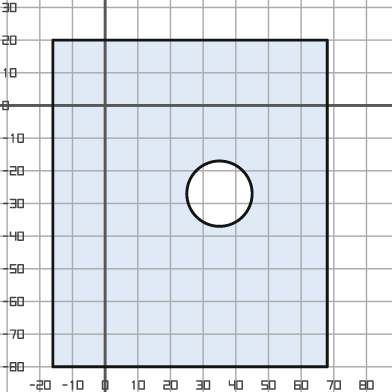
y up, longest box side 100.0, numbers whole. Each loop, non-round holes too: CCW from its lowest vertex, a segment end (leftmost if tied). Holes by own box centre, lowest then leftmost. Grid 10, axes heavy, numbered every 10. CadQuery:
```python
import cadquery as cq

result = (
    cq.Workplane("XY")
    .moveTo(-16.0, -80.0)
    .lineTo(68.0, -80.0)
    .lineTo(68.0, 20.0)
    .lineTo(-16.0, 20.0)
    .close()
    .moveTo(35.0, -27.0)
    .circle(10.0)
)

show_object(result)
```